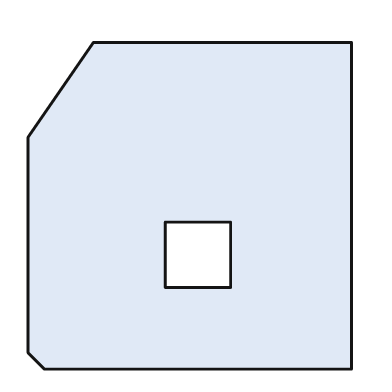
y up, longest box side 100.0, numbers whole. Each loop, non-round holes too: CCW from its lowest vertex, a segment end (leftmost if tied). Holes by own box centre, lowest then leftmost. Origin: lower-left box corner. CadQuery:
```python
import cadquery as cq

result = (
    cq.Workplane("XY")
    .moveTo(5.0, 0.0)
    .lineTo(99.0, 0.0)
    .lineTo(99.0, 100.0)
    .lineTo(20.0, 100.0)
    .lineTo(0.0, 71.0)
    .lineTo(0.0, 5.0)
    .close()
    .moveTo(42.0, 25.0)
    .lineTo(62.0, 25.0)
    .lineTo(62.0, 45.0)
    .lineTo(42.0, 45.0)
    .close()
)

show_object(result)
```